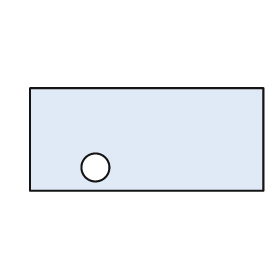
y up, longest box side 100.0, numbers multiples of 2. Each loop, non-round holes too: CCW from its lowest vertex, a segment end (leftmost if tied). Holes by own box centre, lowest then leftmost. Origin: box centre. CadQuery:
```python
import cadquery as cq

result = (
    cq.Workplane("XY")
    .moveTo(-50.0, -22.0)
    .lineTo(50.0, -22.0)
    .lineTo(50.0, 22.0)
    .lineTo(-50.0, 22.0)
    .close()
    .moveTo(-22.0, -12.0)
    .circle(6.0)
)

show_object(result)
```